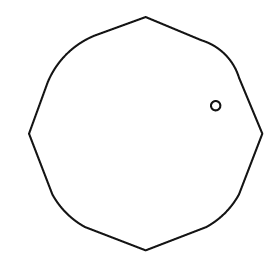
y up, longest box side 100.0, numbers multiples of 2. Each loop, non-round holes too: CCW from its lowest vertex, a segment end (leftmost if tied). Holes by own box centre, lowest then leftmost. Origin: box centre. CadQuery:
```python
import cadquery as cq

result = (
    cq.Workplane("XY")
    .moveTo(0.0, -50.0)
    .lineTo(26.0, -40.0)
    .threePointArc((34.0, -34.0), (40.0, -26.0))
    .lineTo(50.0, 0.0)
    .lineTo(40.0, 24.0)
    .threePointArc((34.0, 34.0), (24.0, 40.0))
    .lineTo(0.0, 50.0)
    .lineTo(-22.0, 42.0)
    .threePointArc((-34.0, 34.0), (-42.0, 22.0))
    .lineTo(-50.0, 0.0)
    .lineTo(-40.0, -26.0)
    .threePointArc((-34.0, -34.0), (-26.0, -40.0))
    .close()
    .moveTo(30.0, 12.0)
    .circle(2.0)
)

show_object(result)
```